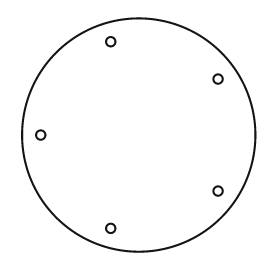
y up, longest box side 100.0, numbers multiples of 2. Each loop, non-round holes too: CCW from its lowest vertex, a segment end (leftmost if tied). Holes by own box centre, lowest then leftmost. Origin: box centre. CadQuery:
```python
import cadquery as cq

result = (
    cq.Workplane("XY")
    .moveTo(0.0, 0.0)
    .circle(50.0)
    .moveTo(-12.0, -40.0)
    .circle(2.0)
    .moveTo(34.0, -24.0)
    .circle(2.0)
    .moveTo(-42.0, 0.0)
    .circle(2.0)
    .moveTo(34.0, 24.0)
    .circle(2.0)
    .moveTo(-12.0, 40.0)
    .circle(2.0)
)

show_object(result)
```